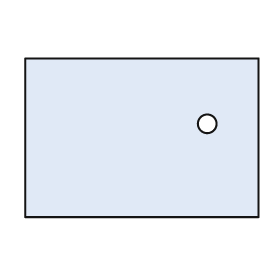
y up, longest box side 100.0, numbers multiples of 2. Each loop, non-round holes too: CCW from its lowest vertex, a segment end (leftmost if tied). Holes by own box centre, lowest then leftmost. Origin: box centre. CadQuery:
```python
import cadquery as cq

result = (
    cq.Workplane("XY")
    .moveTo(-50.0, -34.0)
    .lineTo(50.0, -34.0)
    .lineTo(50.0, 34.0)
    .lineTo(-50.0, 34.0)
    .close()
    .moveTo(28.0, 6.0)
    .circle(4.0)
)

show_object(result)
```